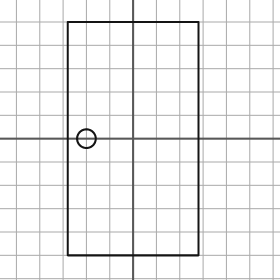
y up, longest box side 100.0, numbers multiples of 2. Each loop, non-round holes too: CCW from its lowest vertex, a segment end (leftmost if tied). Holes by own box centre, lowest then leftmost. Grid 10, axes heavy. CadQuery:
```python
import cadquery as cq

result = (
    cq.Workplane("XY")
    .moveTo(-28.0, -50.0)
    .lineTo(28.0, -50.0)
    .lineTo(28.0, 50.0)
    .lineTo(-28.0, 50.0)
    .close()
    .moveTo(-20.0, 0.0)
    .circle(4.0)
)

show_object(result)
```